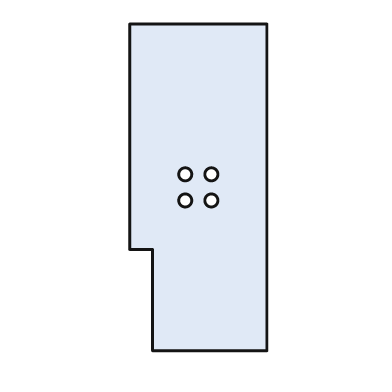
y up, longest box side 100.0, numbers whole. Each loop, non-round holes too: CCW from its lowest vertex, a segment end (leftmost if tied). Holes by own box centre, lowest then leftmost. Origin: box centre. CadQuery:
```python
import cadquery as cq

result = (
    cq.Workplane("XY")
    .moveTo(-14.0, -50.0)
    .lineTo(21.0, -50.0)
    .lineTo(21.0, 50.0)
    .lineTo(-21.0, 50.0)
    .lineTo(-21.0, -19.0)
    .lineTo(-14.0, -19.0)
    .close()
    .moveTo(-4.0, -4.0)
    .circle(2.0)
    .moveTo(4.0, -4.0)
    .circle(2.0)
    .moveTo(-4.0, 4.0)
    .circle(2.0)
    .moveTo(4.0, 4.0)
    .circle(2.0)
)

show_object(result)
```